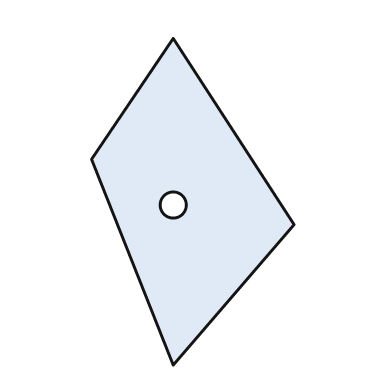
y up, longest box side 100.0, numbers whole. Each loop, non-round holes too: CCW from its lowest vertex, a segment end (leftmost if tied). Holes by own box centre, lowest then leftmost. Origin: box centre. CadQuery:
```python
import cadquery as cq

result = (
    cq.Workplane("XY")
    .moveTo(-6.0, -50.0)
    .lineTo(31.0, -7.0)
    .lineTo(-6.0, 50.0)
    .lineTo(-31.0, 13.0)
    .close()
    .moveTo(-6.0, -1.0)
    .circle(4.0)
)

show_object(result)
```